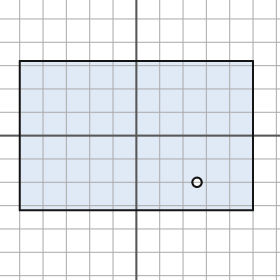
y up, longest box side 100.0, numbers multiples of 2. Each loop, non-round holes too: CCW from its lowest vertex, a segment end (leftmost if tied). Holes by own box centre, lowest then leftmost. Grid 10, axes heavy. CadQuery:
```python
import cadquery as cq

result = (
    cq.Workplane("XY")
    .moveTo(-50.0, -32.0)
    .lineTo(50.0, -32.0)
    .lineTo(50.0, 32.0)
    .lineTo(-50.0, 32.0)
    .close()
    .moveTo(26.0, -20.0)
    .circle(2.0)
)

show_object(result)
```